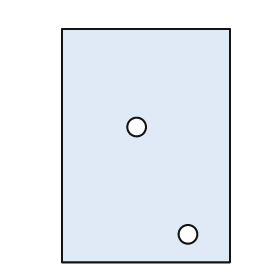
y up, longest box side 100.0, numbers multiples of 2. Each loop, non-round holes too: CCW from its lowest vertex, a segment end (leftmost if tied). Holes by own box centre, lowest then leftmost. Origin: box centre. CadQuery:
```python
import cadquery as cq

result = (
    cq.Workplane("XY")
    .moveTo(-36.0, -50.0)
    .lineTo(36.0, -50.0)
    .lineTo(36.0, 50.0)
    .lineTo(-36.0, 50.0)
    .close()
    .moveTo(18.0, -38.0)
    .circle(4.0)
    .moveTo(-4.0, 8.0)
    .circle(4.0)
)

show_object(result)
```